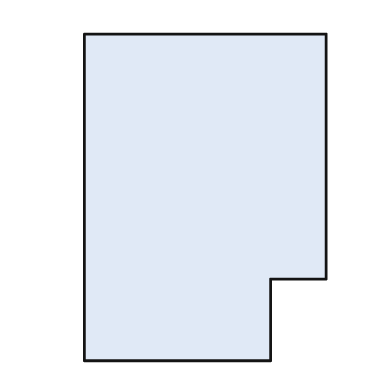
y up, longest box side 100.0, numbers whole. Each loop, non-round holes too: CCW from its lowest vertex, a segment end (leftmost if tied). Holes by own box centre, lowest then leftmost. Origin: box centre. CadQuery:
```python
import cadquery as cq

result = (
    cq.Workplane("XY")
    .moveTo(-37.0, -50.0)
    .lineTo(20.0, -50.0)
    .lineTo(20.0, -25.0)
    .lineTo(37.0, -25.0)
    .lineTo(37.0, 50.0)
    .lineTo(-37.0, 50.0)
    .close()
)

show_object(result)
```